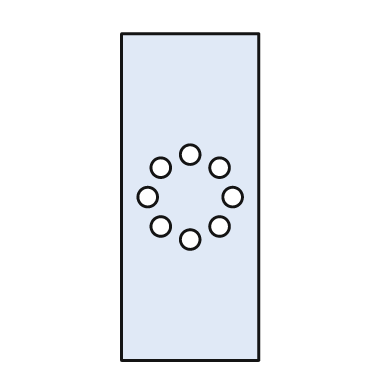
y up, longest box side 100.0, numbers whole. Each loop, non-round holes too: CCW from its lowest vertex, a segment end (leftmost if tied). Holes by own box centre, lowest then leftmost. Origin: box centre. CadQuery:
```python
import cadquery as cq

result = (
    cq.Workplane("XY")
    .moveTo(-21.0, -50.0)
    .lineTo(21.0, -50.0)
    .lineTo(21.0, 50.0)
    .lineTo(-21.0, 50.0)
    .close()
    .moveTo(0.0, -13.0)
    .circle(3.0)
    .moveTo(-9.0, -9.0)
    .circle(3.0)
    .moveTo(9.0, -9.0)
    .circle(3.0)
    .moveTo(-13.0, 0.0)
    .circle(3.0)
    .moveTo(13.0, 0.0)
    .circle(3.0)
    .moveTo(-9.0, 9.0)
    .circle(3.0)
    .moveTo(9.0, 9.0)
    .circle(3.0)
    .moveTo(0.0, 13.0)
    .circle(3.0)
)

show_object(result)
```